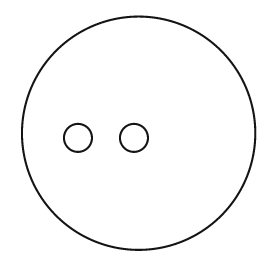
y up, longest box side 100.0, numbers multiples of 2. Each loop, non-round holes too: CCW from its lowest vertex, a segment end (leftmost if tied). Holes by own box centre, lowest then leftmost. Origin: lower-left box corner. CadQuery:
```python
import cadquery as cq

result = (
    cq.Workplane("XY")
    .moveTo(50.0, 50.0)
    .circle(50.0)
    .moveTo(24.0, 48.0)
    .circle(6.0)
    .moveTo(48.0, 48.0)
    .circle(6.0)
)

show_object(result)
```